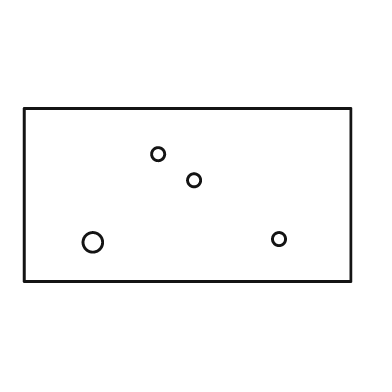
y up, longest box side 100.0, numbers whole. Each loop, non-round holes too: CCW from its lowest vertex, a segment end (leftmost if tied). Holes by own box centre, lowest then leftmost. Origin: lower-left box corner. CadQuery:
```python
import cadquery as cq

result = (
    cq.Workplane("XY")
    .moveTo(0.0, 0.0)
    .lineTo(100.0, 0.0)
    .lineTo(100.0, 53.0)
    .lineTo(0.0, 53.0)
    .close()
    .moveTo(21.0, 12.0)
    .circle(3.0)
    .moveTo(78.0, 13.0)
    .circle(2.0)
    .moveTo(52.0, 31.0)
    .circle(2.0)
    .moveTo(41.0, 39.0)
    .circle(2.0)
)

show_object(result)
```